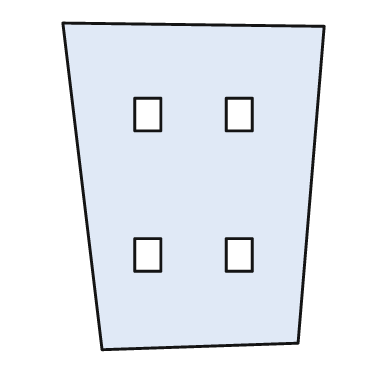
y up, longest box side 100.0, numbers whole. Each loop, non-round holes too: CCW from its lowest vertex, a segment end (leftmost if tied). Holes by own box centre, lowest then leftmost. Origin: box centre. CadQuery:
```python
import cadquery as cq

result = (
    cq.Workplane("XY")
    .moveTo(-28.0, -50.0)
    .lineTo(32.0, -48.0)
    .lineTo(40.0, 49.0)
    .lineTo(-40.0, 50.0)
    .close()
    .moveTo(-18.0, -26.0)
    .lineTo(-10.0, -26.0)
    .lineTo(-10.0, -16.0)
    .lineTo(-18.0, -16.0)
    .close()
    .moveTo(10.0, -26.0)
    .lineTo(18.0, -26.0)
    .lineTo(18.0, -16.0)
    .lineTo(10.0, -16.0)
    .close()
    .moveTo(-18.0, 17.0)
    .lineTo(-10.0, 17.0)
    .lineTo(-10.0, 27.0)
    .lineTo(-18.0, 27.0)
    .close()
    .moveTo(10.0, 17.0)
    .lineTo(18.0, 17.0)
    .lineTo(18.0, 27.0)
    .lineTo(10.0, 27.0)
    .close()
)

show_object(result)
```